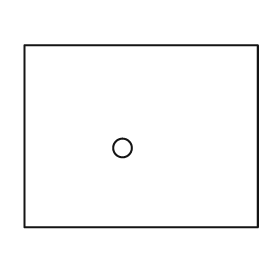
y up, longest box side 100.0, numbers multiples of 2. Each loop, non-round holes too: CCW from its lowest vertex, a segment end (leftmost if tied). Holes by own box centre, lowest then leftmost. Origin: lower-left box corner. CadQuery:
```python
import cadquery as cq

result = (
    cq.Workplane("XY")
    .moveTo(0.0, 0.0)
    .lineTo(100.0, 0.0)
    .lineTo(100.0, 78.0)
    .lineTo(0.0, 78.0)
    .close()
    .moveTo(42.0, 34.0)
    .circle(4.0)
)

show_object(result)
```